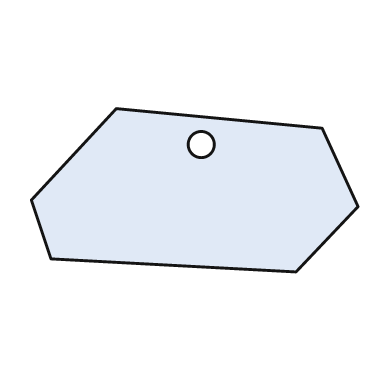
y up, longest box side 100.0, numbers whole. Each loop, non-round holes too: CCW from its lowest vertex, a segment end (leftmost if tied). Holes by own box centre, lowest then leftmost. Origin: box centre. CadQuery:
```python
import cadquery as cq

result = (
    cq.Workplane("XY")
    .moveTo(31.0, -25.0)
    .lineTo(50.0, -5.0)
    .lineTo(39.0, 19.0)
    .lineTo(-24.0, 25.0)
    .lineTo(-50.0, -3.0)
    .lineTo(-44.0, -21.0)
    .close()
    .moveTo(2.0, 14.0)
    .circle(4.0)
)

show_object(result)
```